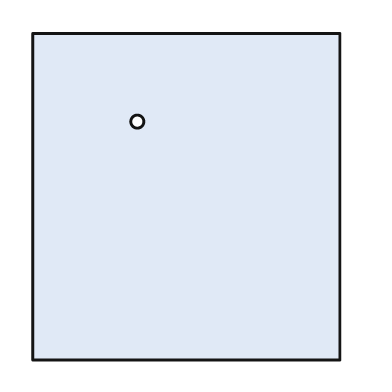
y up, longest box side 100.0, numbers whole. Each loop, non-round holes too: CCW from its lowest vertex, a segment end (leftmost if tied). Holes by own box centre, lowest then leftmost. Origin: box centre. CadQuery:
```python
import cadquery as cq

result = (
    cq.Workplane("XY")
    .moveTo(-47.0, -50.0)
    .lineTo(47.0, -50.0)
    .lineTo(47.0, 50.0)
    .lineTo(-47.0, 50.0)
    .close()
    .moveTo(-15.0, 23.0)
    .circle(2.0)
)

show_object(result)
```